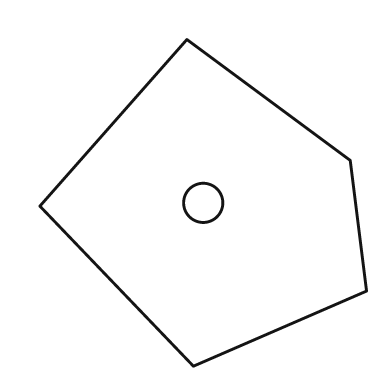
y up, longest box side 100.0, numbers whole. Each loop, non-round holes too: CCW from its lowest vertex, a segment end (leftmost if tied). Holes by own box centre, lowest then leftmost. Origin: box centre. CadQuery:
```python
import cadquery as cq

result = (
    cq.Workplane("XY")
    .moveTo(-3.0, -50.0)
    .lineTo(50.0, -27.0)
    .lineTo(45.0, 13.0)
    .lineTo(-5.0, 50.0)
    .lineTo(-50.0, -1.0)
    .close()
    .moveTo(0.0, 0.0)
    .circle(6.0)
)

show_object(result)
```